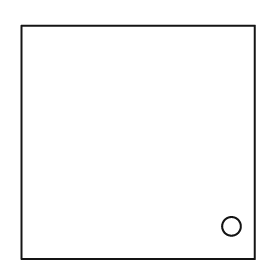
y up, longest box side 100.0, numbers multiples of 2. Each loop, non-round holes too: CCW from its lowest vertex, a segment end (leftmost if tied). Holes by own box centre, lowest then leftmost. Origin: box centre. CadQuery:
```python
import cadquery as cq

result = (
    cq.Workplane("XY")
    .moveTo(-50.0, -50.0)
    .lineTo(50.0, -50.0)
    .lineTo(50.0, 50.0)
    .lineTo(-50.0, 50.0)
    .close()
    .moveTo(40.0, -36.0)
    .circle(4.0)
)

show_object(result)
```